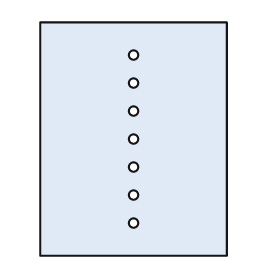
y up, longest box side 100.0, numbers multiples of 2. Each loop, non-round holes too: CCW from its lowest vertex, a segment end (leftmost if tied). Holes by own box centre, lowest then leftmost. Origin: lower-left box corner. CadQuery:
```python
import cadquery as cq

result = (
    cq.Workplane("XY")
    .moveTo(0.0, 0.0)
    .lineTo(80.0, 0.0)
    .lineTo(80.0, 100.0)
    .lineTo(0.0, 100.0)
    .close()
    .moveTo(40.0, 14.0)
    .circle(2.0)
    .moveTo(40.0, 26.0)
    .circle(2.0)
    .moveTo(40.0, 38.0)
    .circle(2.0)
    .moveTo(40.0, 50.0)
    .circle(2.0)
    .moveTo(40.0, 62.0)
    .circle(2.0)
    .moveTo(40.0, 74.0)
    .circle(2.0)
    .moveTo(40.0, 86.0)
    .circle(2.0)
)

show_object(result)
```